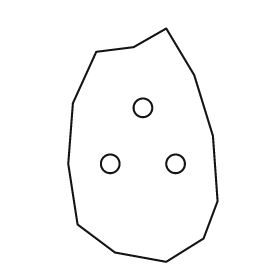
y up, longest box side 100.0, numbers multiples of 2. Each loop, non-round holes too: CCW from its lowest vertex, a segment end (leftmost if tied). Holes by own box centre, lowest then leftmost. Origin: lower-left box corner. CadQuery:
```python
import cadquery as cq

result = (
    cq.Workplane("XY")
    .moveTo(42.0, 0.0)
    .lineTo(58.0, 10.0)
    .lineTo(64.0, 26.0)
    .lineTo(62.0, 54.0)
    .lineTo(54.0, 80.0)
    .lineTo(42.0, 100.0)
    .lineTo(28.0, 92.0)
    .lineTo(12.0, 90.0)
    .lineTo(2.0, 68.0)
    .lineTo(0.0, 42.0)
    .lineTo(4.0, 16.0)
    .lineTo(20.0, 4.0)
    .close()
    .moveTo(18.0, 42.0)
    .circle(4.0)
    .moveTo(46.0, 42.0)
    .circle(4.0)
    .moveTo(32.0, 66.0)
    .circle(4.0)
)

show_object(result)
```